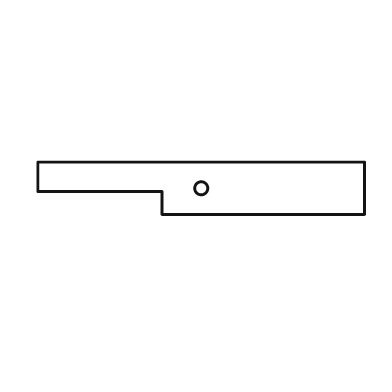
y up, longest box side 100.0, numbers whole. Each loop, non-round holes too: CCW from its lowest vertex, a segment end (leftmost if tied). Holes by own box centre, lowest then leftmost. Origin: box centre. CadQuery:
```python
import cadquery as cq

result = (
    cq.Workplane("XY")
    .moveTo(-12.0, -8.0)
    .lineTo(50.0, -8.0)
    .lineTo(50.0, 8.0)
    .lineTo(-50.0, 8.0)
    .lineTo(-50.0, -1.0)
    .lineTo(-12.0, -1.0)
    .close()
    .moveTo(0.0, 0.0)
    .circle(2.0)
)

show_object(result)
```